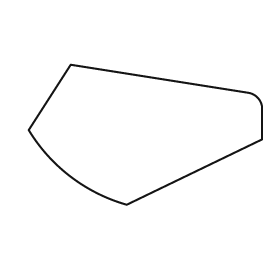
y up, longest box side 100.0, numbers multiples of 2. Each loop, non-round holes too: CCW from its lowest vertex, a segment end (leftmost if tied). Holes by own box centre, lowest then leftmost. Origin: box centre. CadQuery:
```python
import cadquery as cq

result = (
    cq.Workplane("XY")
    .moveTo(-8.0, -30.0)
    .lineTo(50.0, -2.0)
    .lineTo(50.0, 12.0)
    .threePointArc((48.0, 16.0), (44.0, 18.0))
    .lineTo(-32.0, 30.0)
    .lineTo(-50.0, 2.0)
    .threePointArc((-32.0, -18.0), (-8.0, -30.0))
    .close()
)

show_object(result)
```